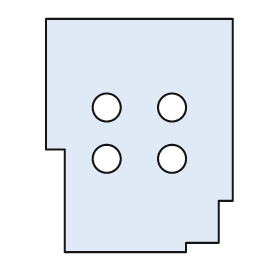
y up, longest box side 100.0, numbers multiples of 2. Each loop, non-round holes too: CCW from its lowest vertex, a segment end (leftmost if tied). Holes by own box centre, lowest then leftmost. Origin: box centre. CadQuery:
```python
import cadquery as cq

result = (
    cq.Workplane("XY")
    .moveTo(-32.0, -50.0)
    .lineTo(20.0, -50.0)
    .lineTo(20.0, -46.0)
    .lineTo(34.0, -46.0)
    .lineTo(34.0, -28.0)
    .lineTo(40.0, -28.0)
    .lineTo(40.0, 50.0)
    .lineTo(-40.0, 50.0)
    .lineTo(-40.0, -6.0)
    .lineTo(-32.0, -6.0)
    .close()
    .moveTo(-14.0, -10.0)
    .circle(6.0)
    .moveTo(14.0, -10.0)
    .circle(6.0)
    .moveTo(-14.0, 12.0)
    .circle(6.0)
    .moveTo(14.0, 12.0)
    .circle(6.0)
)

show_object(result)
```